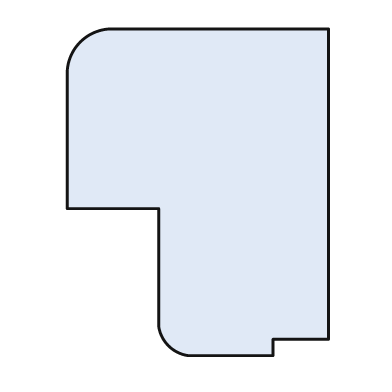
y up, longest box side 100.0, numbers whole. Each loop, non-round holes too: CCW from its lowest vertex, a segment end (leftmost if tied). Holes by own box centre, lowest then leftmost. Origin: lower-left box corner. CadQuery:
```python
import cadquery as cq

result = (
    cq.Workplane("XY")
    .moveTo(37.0, 0.0)
    .lineTo(63.0, 0.0)
    .lineTo(63.0, 5.0)
    .lineTo(80.0, 5.0)
    .lineTo(80.0, 100.0)
    .lineTo(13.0, 100.0)
    .threePointArc((4.0, 96.0), (0.0, 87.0))
    .lineTo(0.0, 45.0)
    .lineTo(28.0, 45.0)
    .lineTo(28.0, 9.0)
    .threePointArc((31.0, 3.0), (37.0, 0.0))
    .close()
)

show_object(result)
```